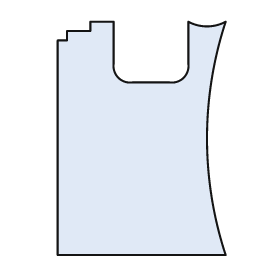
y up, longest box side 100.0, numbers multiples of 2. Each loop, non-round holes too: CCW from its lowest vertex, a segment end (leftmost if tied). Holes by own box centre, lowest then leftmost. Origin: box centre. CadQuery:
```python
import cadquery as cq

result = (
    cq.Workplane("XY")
    .moveTo(-36.0, -50.0)
    .lineTo(36.0, -50.0)
    .threePointArc((28.0, 0.0), (36.0, 50.0))
    .threePointArc((28.0, 48.0), (20.0, 50.0))
    .lineTo(20.0, 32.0)
    .threePointArc((18.0, 26.0), (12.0, 24.0))
    .lineTo(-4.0, 24.0)
    .threePointArc((-10.0, 26.0), (-12.0, 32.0))
    .lineTo(-12.0, 50.0)
    .lineTo(-22.0, 50.0)
    .lineTo(-22.0, 46.0)
    .lineTo(-32.0, 46.0)
    .lineTo(-32.0, 42.0)
    .lineTo(-36.0, 42.0)
    .close()
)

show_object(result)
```